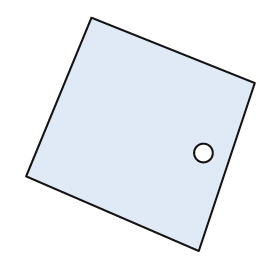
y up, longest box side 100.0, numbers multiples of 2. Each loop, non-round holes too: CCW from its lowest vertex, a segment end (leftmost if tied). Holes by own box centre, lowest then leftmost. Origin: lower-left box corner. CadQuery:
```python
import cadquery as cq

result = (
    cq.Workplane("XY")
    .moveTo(74.0, 0.0)
    .lineTo(98.0, 72.0)
    .lineTo(28.0, 100.0)
    .lineTo(0.0, 32.0)
    .close()
    .moveTo(76.0, 42.0)
    .circle(4.0)
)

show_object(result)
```